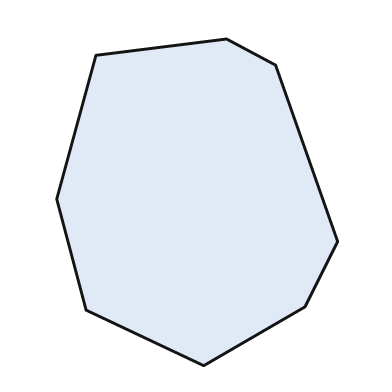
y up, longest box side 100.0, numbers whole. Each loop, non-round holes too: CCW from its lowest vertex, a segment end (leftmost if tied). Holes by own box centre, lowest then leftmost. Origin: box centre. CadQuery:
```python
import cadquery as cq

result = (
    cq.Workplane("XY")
    .moveTo(2.0, -50.0)
    .lineTo(33.0, -32.0)
    .lineTo(43.0, -12.0)
    .lineTo(24.0, 42.0)
    .lineTo(9.0, 50.0)
    .lineTo(-31.0, 45.0)
    .lineTo(-43.0, 1.0)
    .lineTo(-34.0, -33.0)
    .close()
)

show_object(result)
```